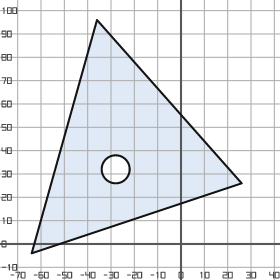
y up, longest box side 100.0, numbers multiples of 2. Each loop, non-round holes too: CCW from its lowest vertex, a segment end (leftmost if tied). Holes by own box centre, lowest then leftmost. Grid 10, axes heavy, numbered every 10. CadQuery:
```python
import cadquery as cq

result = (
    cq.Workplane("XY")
    .moveTo(-64.0, -4.0)
    .lineTo(26.0, 26.0)
    .lineTo(-36.0, 96.0)
    .close()
    .moveTo(-28.0, 32.0)
    .circle(6.0)
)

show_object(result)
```